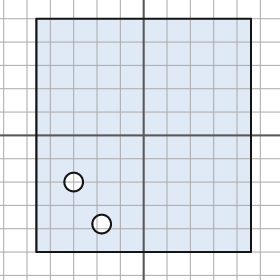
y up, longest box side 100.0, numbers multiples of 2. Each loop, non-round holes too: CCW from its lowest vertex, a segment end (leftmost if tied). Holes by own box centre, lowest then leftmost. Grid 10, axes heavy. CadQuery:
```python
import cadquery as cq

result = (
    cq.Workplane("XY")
    .moveTo(-46.0, -50.0)
    .lineTo(46.0, -50.0)
    .lineTo(46.0, 50.0)
    .lineTo(-46.0, 50.0)
    .close()
    .moveTo(-18.0, -38.0)
    .circle(4.0)
    .moveTo(-30.0, -20.0)
    .circle(4.0)
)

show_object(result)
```